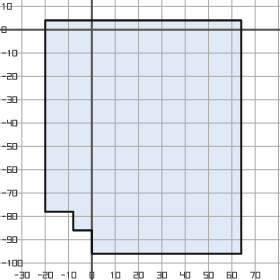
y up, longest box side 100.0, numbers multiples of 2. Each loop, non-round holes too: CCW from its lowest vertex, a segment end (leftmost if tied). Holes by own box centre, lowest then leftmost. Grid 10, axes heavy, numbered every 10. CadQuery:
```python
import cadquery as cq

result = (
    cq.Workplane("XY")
    .moveTo(0.0, -96.0)
    .lineTo(64.0, -96.0)
    .lineTo(64.0, 4.0)
    .lineTo(-20.0, 4.0)
    .lineTo(-20.0, -78.0)
    .lineTo(-8.0, -78.0)
    .lineTo(-8.0, -86.0)
    .lineTo(0.0, -86.0)
    .close()
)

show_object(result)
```